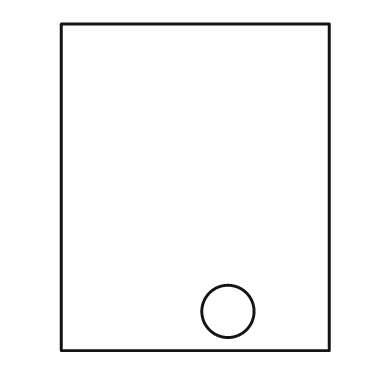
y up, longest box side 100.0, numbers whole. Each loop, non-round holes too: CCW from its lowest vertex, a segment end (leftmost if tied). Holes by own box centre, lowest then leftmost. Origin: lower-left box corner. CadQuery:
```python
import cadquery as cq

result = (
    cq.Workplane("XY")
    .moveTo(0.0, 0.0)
    .lineTo(82.0, 0.0)
    .lineTo(82.0, 100.0)
    .lineTo(0.0, 100.0)
    .close()
    .moveTo(51.0, 12.0)
    .circle(8.0)
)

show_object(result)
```